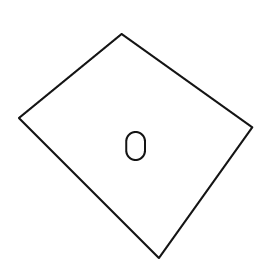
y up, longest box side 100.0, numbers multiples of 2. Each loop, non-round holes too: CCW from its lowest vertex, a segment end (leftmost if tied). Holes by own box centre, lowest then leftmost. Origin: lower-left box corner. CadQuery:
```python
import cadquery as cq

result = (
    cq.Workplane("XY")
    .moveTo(60.0, 0.0)
    .lineTo(100.0, 56.0)
    .lineTo(44.0, 96.0)
    .lineTo(0.0, 60.0)
    .close()
    .moveTo(46.0, 46.0)
    .threePointArc((50.0, 42.0), (54.0, 46.0))
    .lineTo(54.0, 50.0)
    .threePointArc((50.0, 54.0), (46.0, 50.0))
    .close()
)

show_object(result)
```